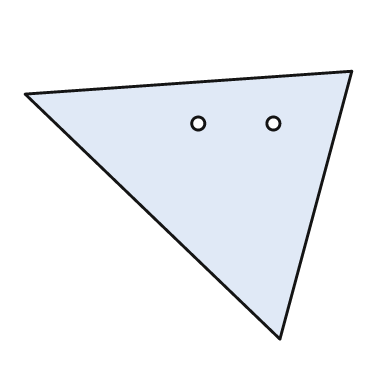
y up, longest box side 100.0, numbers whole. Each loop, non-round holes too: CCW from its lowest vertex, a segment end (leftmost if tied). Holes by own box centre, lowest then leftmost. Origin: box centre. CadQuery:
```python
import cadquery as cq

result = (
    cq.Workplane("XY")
    .moveTo(28.0, -41.0)
    .lineTo(50.0, 41.0)
    .lineTo(-50.0, 34.0)
    .close()
    .moveTo(3.0, 25.0)
    .circle(2.0)
    .moveTo(26.0, 25.0)
    .circle(2.0)
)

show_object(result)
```